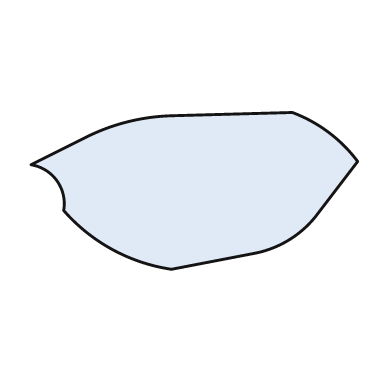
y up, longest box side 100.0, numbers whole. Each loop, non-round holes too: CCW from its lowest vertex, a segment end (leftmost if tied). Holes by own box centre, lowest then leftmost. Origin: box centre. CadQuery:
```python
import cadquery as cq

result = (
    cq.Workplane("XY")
    .moveTo(-7.0, -24.0)
    .lineTo(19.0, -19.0)
    .threePointArc((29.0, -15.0), (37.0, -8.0))
    .lineTo(50.0, 9.0)
    .threePointArc((41.0, 18.0), (30.0, 24.0))
    .lineTo(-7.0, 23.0)
    .threePointArc((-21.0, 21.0), (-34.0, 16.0))
    .lineTo(-50.0, 8.0)
    .threePointArc((-42.0, 3.0), (-40.0, -6.0))
    .threePointArc((-25.0, -18.0), (-7.0, -24.0))
    .close()
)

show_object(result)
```